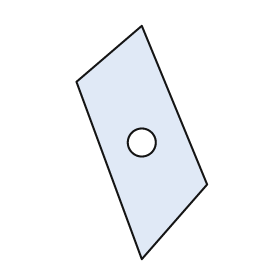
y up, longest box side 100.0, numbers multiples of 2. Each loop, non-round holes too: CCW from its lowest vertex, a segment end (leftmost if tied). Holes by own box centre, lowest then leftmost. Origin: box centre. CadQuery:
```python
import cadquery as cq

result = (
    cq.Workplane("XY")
    .moveTo(0.0, -50.0)
    .lineTo(28.0, -18.0)
    .lineTo(0.0, 50.0)
    .lineTo(-28.0, 26.0)
    .close()
    .moveTo(0.0, 0.0)
    .circle(6.0)
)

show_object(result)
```